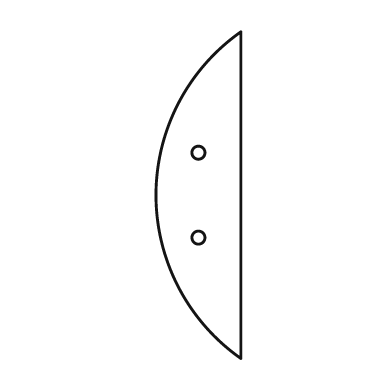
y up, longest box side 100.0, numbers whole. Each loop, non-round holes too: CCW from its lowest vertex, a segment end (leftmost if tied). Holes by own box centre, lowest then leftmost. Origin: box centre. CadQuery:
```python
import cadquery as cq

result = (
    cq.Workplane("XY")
    .moveTo(13.0, -50.0)
    .lineTo(13.0, 50.0)
    .threePointArc((-13.0, 0.0), (13.0, -50.0))
    .close()
    .moveTo(0.0, -13.0)
    .circle(2.0)
    .moveTo(0.0, 13.0)
    .circle(2.0)
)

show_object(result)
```